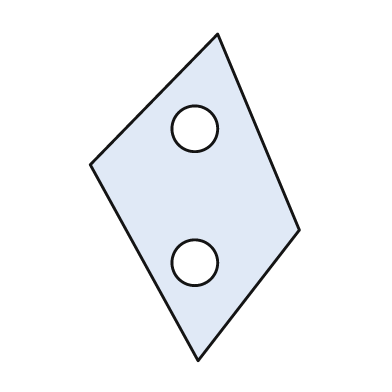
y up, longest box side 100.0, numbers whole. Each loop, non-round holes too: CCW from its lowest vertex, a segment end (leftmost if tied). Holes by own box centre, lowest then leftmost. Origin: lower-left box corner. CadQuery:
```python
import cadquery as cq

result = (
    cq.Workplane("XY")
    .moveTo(33.0, 0.0)
    .lineTo(64.0, 40.0)
    .lineTo(39.0, 100.0)
    .lineTo(0.0, 60.0)
    .close()
    .moveTo(32.0, 30.0)
    .circle(7.0)
    .moveTo(32.0, 71.0)
    .circle(7.0)
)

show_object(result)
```